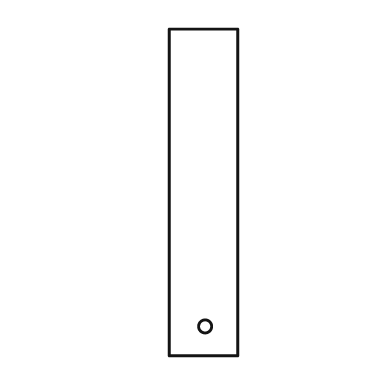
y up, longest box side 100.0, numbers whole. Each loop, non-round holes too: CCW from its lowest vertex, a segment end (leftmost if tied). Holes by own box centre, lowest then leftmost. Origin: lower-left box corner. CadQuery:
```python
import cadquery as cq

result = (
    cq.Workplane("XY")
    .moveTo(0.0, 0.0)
    .lineTo(21.0, 0.0)
    .lineTo(21.0, 100.0)
    .lineTo(0.0, 100.0)
    .close()
    .moveTo(11.0, 9.0)
    .circle(2.0)
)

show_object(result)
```